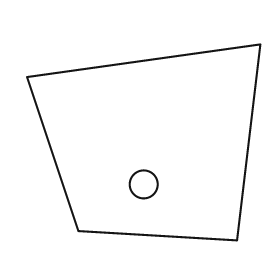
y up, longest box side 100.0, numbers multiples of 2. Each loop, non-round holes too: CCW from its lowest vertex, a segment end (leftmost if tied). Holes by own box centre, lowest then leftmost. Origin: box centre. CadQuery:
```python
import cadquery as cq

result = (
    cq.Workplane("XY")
    .moveTo(40.0, -42.0)
    .lineTo(50.0, 42.0)
    .lineTo(-50.0, 28.0)
    .lineTo(-28.0, -38.0)
    .close()
    .moveTo(0.0, -18.0)
    .circle(6.0)
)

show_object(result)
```